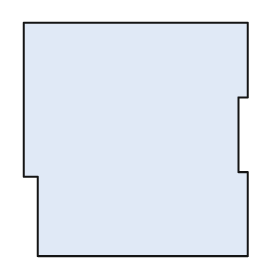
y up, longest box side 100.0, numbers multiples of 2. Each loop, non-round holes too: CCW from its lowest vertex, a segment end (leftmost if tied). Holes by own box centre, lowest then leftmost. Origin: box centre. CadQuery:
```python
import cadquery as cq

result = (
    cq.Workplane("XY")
    .moveTo(-42.0, -50.0)
    .lineTo(48.0, -50.0)
    .lineTo(48.0, -14.0)
    .lineTo(44.0, -14.0)
    .lineTo(44.0, 18.0)
    .lineTo(48.0, 18.0)
    .lineTo(48.0, 50.0)
    .lineTo(-48.0, 50.0)
    .lineTo(-48.0, -16.0)
    .lineTo(-42.0, -16.0)
    .close()
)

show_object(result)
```